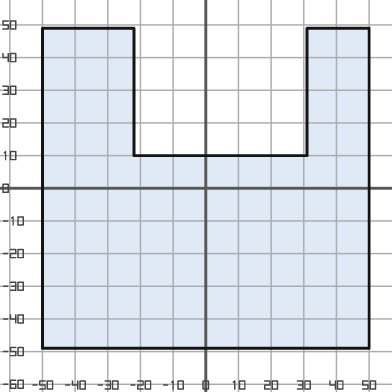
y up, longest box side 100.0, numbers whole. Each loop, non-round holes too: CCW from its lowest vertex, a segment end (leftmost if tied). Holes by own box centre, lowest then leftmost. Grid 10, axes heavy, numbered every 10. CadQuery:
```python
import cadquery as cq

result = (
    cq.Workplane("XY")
    .moveTo(-50.0, -49.0)
    .lineTo(50.0, -49.0)
    .lineTo(50.0, 49.0)
    .lineTo(31.0, 49.0)
    .lineTo(31.0, 10.0)
    .lineTo(-22.0, 10.0)
    .lineTo(-22.0, 49.0)
    .lineTo(-50.0, 49.0)
    .close()
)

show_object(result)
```